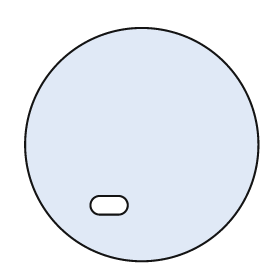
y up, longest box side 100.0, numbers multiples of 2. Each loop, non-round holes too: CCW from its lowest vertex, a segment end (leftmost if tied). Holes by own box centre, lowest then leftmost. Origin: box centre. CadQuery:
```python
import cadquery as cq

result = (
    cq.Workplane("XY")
    .moveTo(0.0, 0.0)
    .circle(50.0)
    .moveTo(-18.0, -30.0)
    .lineTo(-10.0, -30.0)
    .threePointArc((-6.0, -26.0), (-10.0, -22.0))
    .lineTo(-18.0, -22.0)
    .threePointArc((-22.0, -26.0), (-18.0, -30.0))
    .close()
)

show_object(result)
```